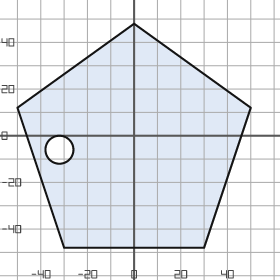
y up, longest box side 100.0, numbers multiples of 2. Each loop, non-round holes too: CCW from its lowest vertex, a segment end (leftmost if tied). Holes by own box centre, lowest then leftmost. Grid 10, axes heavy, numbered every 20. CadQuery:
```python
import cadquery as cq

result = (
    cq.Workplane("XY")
    .moveTo(-30.0, -48.0)
    .lineTo(30.0, -48.0)
    .lineTo(50.0, 12.0)
    .lineTo(0.0, 48.0)
    .lineTo(-50.0, 12.0)
    .close()
    .moveTo(-32.0, -6.0)
    .circle(6.0)
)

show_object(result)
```